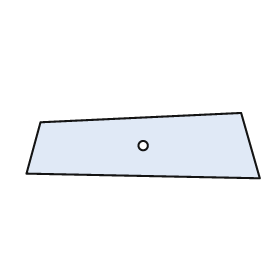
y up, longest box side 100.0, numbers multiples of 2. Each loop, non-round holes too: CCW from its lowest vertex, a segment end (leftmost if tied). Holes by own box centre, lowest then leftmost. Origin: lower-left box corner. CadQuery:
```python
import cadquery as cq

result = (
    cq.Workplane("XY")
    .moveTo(100.0, 0.0)
    .lineTo(92.0, 28.0)
    .lineTo(6.0, 24.0)
    .lineTo(0.0, 2.0)
    .close()
    .moveTo(50.0, 14.0)
    .circle(2.0)
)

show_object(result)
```